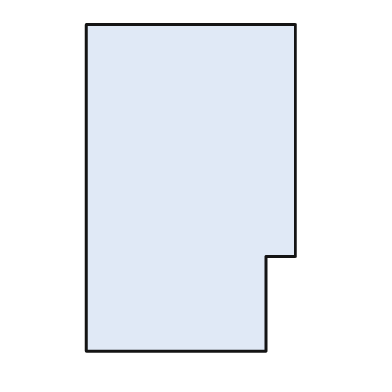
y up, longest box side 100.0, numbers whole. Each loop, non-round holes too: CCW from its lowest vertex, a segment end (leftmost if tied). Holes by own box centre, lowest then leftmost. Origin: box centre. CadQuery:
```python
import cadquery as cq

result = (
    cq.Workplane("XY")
    .moveTo(-32.0, -50.0)
    .lineTo(23.0, -50.0)
    .lineTo(23.0, -21.0)
    .lineTo(32.0, -21.0)
    .lineTo(32.0, 50.0)
    .lineTo(-32.0, 50.0)
    .close()
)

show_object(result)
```